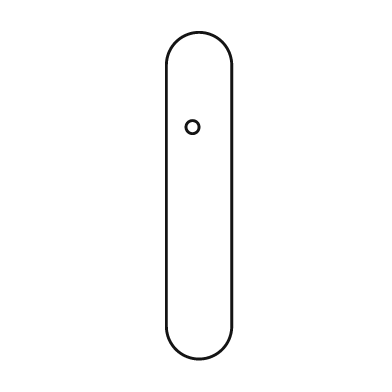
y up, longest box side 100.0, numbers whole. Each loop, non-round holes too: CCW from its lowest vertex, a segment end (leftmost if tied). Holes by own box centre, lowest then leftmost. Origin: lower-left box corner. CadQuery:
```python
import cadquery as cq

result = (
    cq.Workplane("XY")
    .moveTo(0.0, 10.0)
    .threePointArc((10.0, 0.0), (20.0, 10.0))
    .lineTo(20.0, 90.0)
    .threePointArc((10.0, 100.0), (0.0, 90.0))
    .close()
    .moveTo(8.0, 71.0)
    .circle(2.0)
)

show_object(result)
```